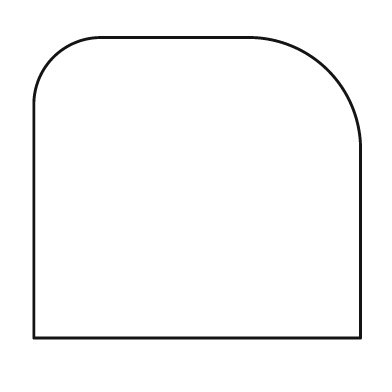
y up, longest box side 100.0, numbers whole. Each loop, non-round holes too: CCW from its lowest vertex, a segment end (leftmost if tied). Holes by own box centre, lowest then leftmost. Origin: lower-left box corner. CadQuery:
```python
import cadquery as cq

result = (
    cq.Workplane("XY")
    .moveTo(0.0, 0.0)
    .lineTo(100.0, 0.0)
    .lineTo(100.0, 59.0)
    .threePointArc((90.0, 82.0), (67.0, 92.0))
    .lineTo(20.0, 92.0)
    .threePointArc((6.0, 86.0), (0.0, 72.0))
    .close()
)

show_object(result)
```